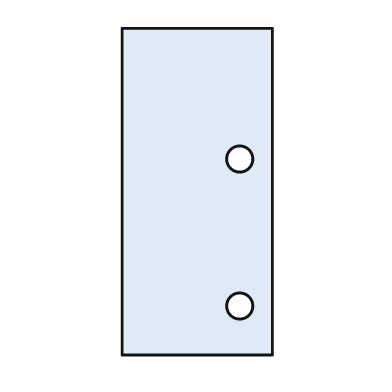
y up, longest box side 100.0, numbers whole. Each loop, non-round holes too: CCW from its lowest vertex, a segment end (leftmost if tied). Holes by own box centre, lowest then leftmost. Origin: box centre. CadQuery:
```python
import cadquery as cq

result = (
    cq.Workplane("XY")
    .moveTo(-23.0, -50.0)
    .lineTo(23.0, -50.0)
    .lineTo(23.0, 50.0)
    .lineTo(-23.0, 50.0)
    .close()
    .moveTo(13.0, -35.0)
    .circle(4.0)
    .moveTo(13.0, 10.0)
    .circle(4.0)
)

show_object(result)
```